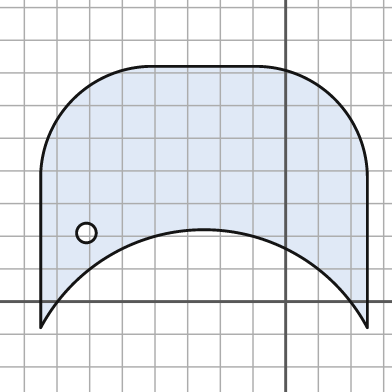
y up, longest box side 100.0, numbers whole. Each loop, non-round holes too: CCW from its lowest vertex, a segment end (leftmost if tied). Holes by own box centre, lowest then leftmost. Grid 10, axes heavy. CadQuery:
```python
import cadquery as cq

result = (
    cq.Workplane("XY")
    .moveTo(-75.0, -8.0)
    .threePointArc((-25.0, 22.0), (25.0, -8.0))
    .lineTo(25.0, 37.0)
    .threePointArc((15.0, 62.0), (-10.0, 72.0))
    .lineTo(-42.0, 72.0)
    .threePointArc((-65.0, 62.0), (-75.0, 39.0))
    .close()
    .moveTo(-61.0, 21.0)
    .circle(3.0)
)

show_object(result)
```